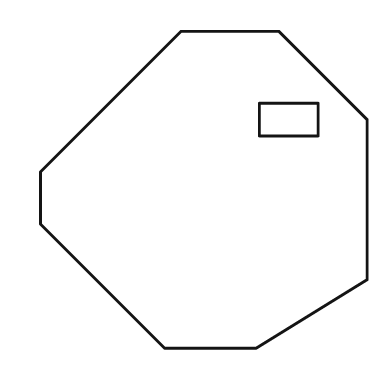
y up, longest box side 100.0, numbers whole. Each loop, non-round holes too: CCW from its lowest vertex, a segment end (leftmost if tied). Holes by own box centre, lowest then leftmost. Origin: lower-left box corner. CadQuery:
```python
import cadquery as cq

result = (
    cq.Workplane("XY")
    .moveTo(38.0, 0.0)
    .lineTo(66.0, 0.0)
    .lineTo(100.0, 21.0)
    .lineTo(100.0, 70.0)
    .lineTo(73.0, 97.0)
    .lineTo(43.0, 97.0)
    .lineTo(0.0, 54.0)
    .lineTo(0.0, 38.0)
    .close()
    .moveTo(67.0, 65.0)
    .lineTo(85.0, 65.0)
    .lineTo(85.0, 75.0)
    .lineTo(67.0, 75.0)
    .close()
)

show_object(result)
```